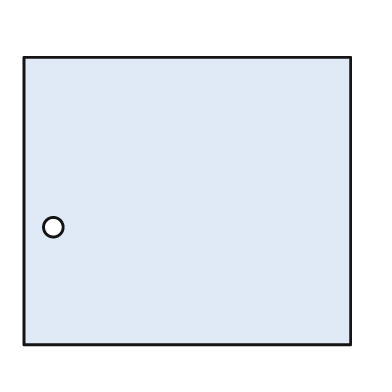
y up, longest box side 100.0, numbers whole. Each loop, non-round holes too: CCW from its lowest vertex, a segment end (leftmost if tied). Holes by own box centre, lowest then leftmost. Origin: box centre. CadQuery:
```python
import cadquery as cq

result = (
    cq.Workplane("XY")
    .moveTo(-50.0, -44.0)
    .lineTo(50.0, -44.0)
    .lineTo(50.0, 44.0)
    .lineTo(-50.0, 44.0)
    .close()
    .moveTo(-41.0, -8.0)
    .circle(3.0)
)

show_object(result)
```